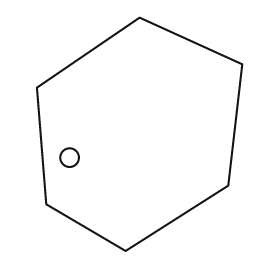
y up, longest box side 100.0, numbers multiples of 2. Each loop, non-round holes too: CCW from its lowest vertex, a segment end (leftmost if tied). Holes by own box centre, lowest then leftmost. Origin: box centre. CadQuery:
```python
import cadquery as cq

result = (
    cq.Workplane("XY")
    .moveTo(-6.0, -50.0)
    .lineTo(38.0, -22.0)
    .lineTo(44.0, 30.0)
    .lineTo(0.0, 50.0)
    .lineTo(-44.0, 20.0)
    .lineTo(-40.0, -30.0)
    .close()
    .moveTo(-30.0, -10.0)
    .circle(4.0)
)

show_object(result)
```